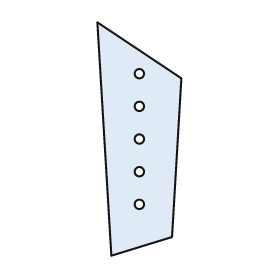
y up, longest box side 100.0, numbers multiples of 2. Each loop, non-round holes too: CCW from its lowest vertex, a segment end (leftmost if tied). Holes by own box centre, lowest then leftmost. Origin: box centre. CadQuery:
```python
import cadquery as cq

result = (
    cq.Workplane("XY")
    .moveTo(-12.0, -50.0)
    .lineTo(14.0, -42.0)
    .lineTo(18.0, 26.0)
    .lineTo(-18.0, 50.0)
    .close()
    .moveTo(0.0, -28.0)
    .circle(2.0)
    .moveTo(0.0, -14.0)
    .circle(2.0)
    .moveTo(0.0, 0.0)
    .circle(2.0)
    .moveTo(0.0, 14.0)
    .circle(2.0)
    .moveTo(0.0, 28.0)
    .circle(2.0)
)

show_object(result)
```